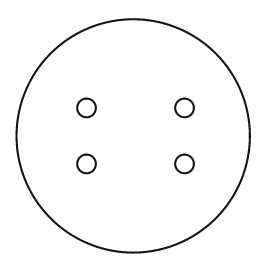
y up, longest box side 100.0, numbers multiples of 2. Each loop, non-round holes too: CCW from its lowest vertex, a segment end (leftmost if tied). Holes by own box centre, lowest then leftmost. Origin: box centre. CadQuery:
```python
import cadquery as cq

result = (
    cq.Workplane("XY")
    .moveTo(0.0, 0.0)
    .circle(50.0)
    .moveTo(-20.0, -12.0)
    .circle(4.0)
    .moveTo(22.0, -12.0)
    .circle(4.0)
    .moveTo(-20.0, 12.0)
    .circle(4.0)
    .moveTo(22.0, 12.0)
    .circle(4.0)
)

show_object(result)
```